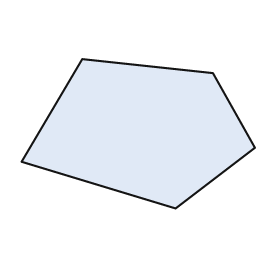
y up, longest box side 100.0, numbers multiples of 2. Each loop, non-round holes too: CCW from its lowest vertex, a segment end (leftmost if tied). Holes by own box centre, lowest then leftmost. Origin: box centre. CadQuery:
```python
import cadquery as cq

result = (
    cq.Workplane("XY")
    .moveTo(16.0, -32.0)
    .lineTo(50.0, -6.0)
    .lineTo(32.0, 26.0)
    .lineTo(-24.0, 32.0)
    .lineTo(-50.0, -12.0)
    .close()
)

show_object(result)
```